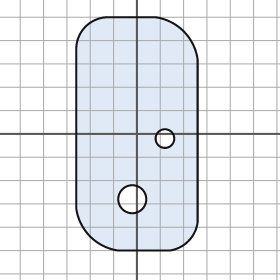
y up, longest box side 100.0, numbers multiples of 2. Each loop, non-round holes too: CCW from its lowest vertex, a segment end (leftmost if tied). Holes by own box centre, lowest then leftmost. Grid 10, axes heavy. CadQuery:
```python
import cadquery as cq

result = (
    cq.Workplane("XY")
    .moveTo(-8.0, -50.0)
    .lineTo(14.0, -50.0)
    .threePointArc((22.0, -46.0), (26.0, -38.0))
    .lineTo(26.0, 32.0)
    .threePointArc((20.0, 44.0), (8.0, 50.0))
    .lineTo(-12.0, 50.0)
    .threePointArc((-22.0, 46.0), (-26.0, 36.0))
    .lineTo(-26.0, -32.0)
    .threePointArc((-20.0, -44.0), (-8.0, -50.0))
    .close()
    .moveTo(-2.0, -28.0)
    .circle(6.0)
    .moveTo(12.0, -2.0)
    .circle(4.0)
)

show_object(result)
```